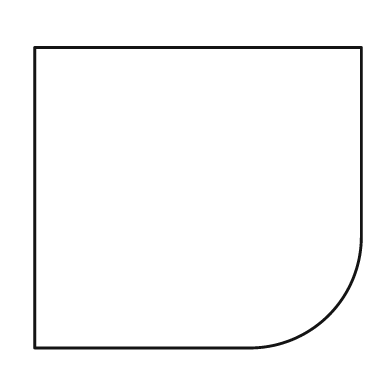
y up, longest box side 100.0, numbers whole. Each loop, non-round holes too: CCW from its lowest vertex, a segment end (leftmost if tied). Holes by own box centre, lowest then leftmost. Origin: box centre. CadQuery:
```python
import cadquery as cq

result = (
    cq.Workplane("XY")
    .moveTo(-50.0, -46.0)
    .lineTo(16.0, -46.0)
    .threePointArc((40.0, -36.0), (50.0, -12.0))
    .lineTo(50.0, 46.0)
    .lineTo(-50.0, 46.0)
    .close()
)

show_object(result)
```